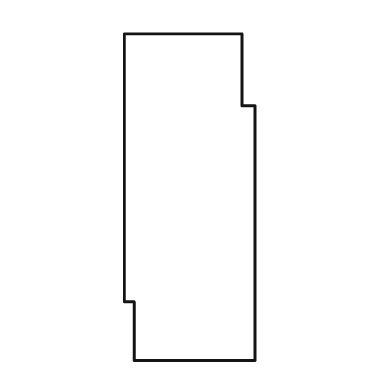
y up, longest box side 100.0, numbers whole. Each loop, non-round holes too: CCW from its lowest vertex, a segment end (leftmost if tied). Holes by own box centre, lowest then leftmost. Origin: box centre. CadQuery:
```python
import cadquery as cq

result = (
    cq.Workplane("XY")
    .moveTo(-17.0, -50.0)
    .lineTo(20.0, -50.0)
    .lineTo(20.0, 28.0)
    .lineTo(16.0, 28.0)
    .lineTo(16.0, 50.0)
    .lineTo(-20.0, 50.0)
    .lineTo(-20.0, -32.0)
    .lineTo(-17.0, -32.0)
    .close()
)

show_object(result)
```